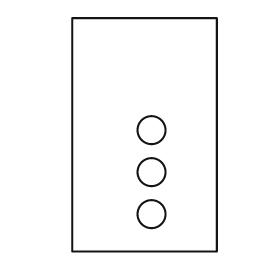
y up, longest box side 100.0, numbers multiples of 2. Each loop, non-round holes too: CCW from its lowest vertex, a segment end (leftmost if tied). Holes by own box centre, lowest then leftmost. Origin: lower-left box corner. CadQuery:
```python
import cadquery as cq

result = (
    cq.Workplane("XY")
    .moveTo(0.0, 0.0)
    .lineTo(62.0, 0.0)
    .lineTo(62.0, 100.0)
    .lineTo(0.0, 100.0)
    .close()
    .moveTo(34.0, 16.0)
    .circle(6.0)
    .moveTo(34.0, 34.0)
    .circle(6.0)
    .moveTo(34.0, 52.0)
    .circle(6.0)
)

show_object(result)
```